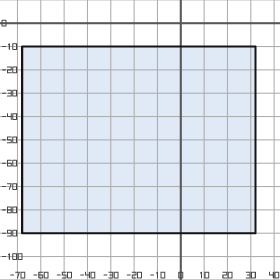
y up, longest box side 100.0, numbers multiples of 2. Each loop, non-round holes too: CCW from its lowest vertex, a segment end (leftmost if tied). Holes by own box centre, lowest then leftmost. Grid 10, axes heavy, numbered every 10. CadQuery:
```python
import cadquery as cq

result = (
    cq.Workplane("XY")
    .moveTo(-68.0, -90.0)
    .lineTo(32.0, -90.0)
    .lineTo(32.0, -10.0)
    .lineTo(-68.0, -10.0)
    .close()
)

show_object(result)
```